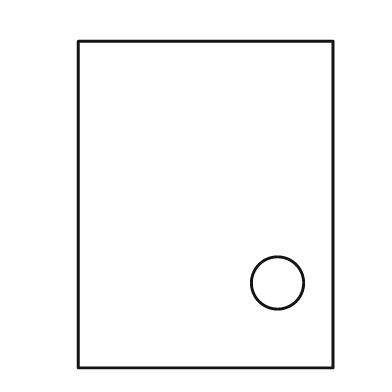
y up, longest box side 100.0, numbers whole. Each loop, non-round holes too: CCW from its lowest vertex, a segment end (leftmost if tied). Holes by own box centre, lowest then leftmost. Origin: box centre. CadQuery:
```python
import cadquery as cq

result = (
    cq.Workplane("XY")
    .moveTo(-39.0, -50.0)
    .lineTo(39.0, -50.0)
    .lineTo(39.0, 50.0)
    .lineTo(-39.0, 50.0)
    .close()
    .moveTo(22.0, -24.0)
    .circle(8.0)
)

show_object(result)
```